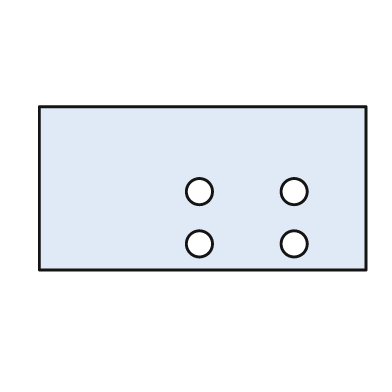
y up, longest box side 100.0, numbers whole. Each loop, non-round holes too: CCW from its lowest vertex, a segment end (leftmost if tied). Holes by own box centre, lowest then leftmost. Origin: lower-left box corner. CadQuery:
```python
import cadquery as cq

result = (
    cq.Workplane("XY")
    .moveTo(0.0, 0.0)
    .lineTo(100.0, 0.0)
    .lineTo(100.0, 50.0)
    .lineTo(0.0, 50.0)
    .close()
    .moveTo(49.0, 8.0)
    .circle(4.0)
    .moveTo(78.0, 8.0)
    .circle(4.0)
    .moveTo(49.0, 24.0)
    .circle(4.0)
    .moveTo(78.0, 24.0)
    .circle(4.0)
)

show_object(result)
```